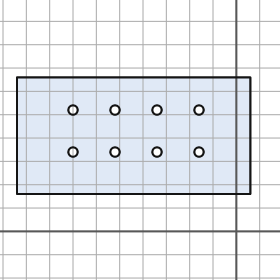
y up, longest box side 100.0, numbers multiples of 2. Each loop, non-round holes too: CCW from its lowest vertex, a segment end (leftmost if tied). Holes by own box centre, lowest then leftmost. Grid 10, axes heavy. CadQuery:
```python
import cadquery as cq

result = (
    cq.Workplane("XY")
    .moveTo(-94.0, 16.0)
    .lineTo(6.0, 16.0)
    .lineTo(6.0, 66.0)
    .lineTo(-94.0, 66.0)
    .close()
    .moveTo(-70.0, 34.0)
    .circle(2.0)
    .moveTo(-52.0, 34.0)
    .circle(2.0)
    .moveTo(-34.0, 34.0)
    .circle(2.0)
    .moveTo(-16.0, 34.0)
    .circle(2.0)
    .moveTo(-70.0, 52.0)
    .circle(2.0)
    .moveTo(-52.0, 52.0)
    .circle(2.0)
    .moveTo(-34.0, 52.0)
    .circle(2.0)
    .moveTo(-16.0, 52.0)
    .circle(2.0)
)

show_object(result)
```